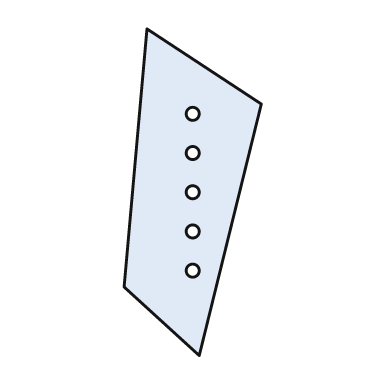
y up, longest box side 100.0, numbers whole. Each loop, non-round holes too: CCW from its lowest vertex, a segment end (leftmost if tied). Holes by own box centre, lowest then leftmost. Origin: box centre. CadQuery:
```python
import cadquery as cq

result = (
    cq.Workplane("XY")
    .moveTo(2.0, -50.0)
    .lineTo(21.0, 27.0)
    .lineTo(-14.0, 50.0)
    .lineTo(-21.0, -29.0)
    .close()
    .moveTo(0.0, -24.0)
    .circle(2.0)
    .moveTo(0.0, -12.0)
    .circle(2.0)
    .moveTo(0.0, 0.0)
    .circle(2.0)
    .moveTo(0.0, 12.0)
    .circle(2.0)
    .moveTo(0.0, 24.0)
    .circle(2.0)
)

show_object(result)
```